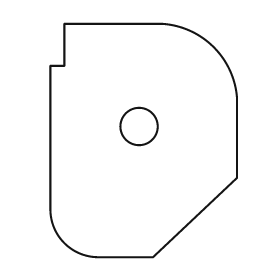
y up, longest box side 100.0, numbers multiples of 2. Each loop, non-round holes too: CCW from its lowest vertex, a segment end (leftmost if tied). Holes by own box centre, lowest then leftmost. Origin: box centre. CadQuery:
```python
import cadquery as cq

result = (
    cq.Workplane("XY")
    .moveTo(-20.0, -50.0)
    .lineTo(4.0, -50.0)
    .lineTo(40.0, -16.0)
    .lineTo(40.0, 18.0)
    .threePointArc((30.0, 40.0), (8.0, 50.0))
    .lineTo(-34.0, 50.0)
    .lineTo(-34.0, 32.0)
    .lineTo(-40.0, 32.0)
    .lineTo(-40.0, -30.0)
    .threePointArc((-34.0, -44.0), (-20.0, -50.0))
    .close()
    .moveTo(-2.0, 6.0)
    .circle(8.0)
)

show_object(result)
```